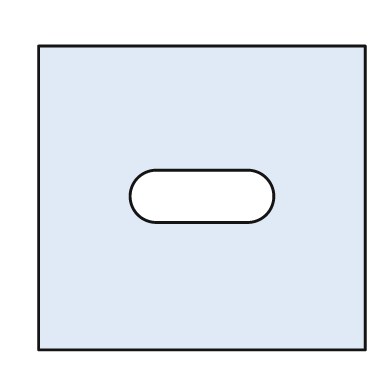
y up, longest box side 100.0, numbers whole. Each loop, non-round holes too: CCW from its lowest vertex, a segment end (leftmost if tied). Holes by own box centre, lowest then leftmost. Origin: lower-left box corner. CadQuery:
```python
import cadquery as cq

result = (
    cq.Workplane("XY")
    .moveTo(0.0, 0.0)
    .lineTo(100.0, 0.0)
    .lineTo(100.0, 93.0)
    .lineTo(0.0, 93.0)
    .close()
    .moveTo(36.0, 39.0)
    .lineTo(64.0, 39.0)
    .threePointArc((72.0, 47.0), (64.0, 55.0))
    .lineTo(36.0, 55.0)
    .threePointArc((28.0, 47.0), (36.0, 39.0))
    .close()
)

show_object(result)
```